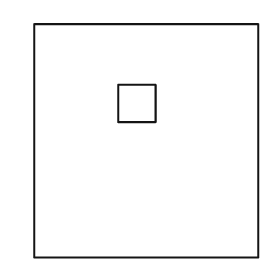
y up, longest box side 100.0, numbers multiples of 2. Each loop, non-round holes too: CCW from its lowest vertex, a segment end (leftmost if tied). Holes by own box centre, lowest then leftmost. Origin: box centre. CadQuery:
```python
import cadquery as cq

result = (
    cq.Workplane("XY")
    .moveTo(-48.0, -50.0)
    .lineTo(48.0, -50.0)
    .lineTo(48.0, 50.0)
    .lineTo(-48.0, 50.0)
    .close()
    .moveTo(-12.0, 8.0)
    .lineTo(4.0, 8.0)
    .lineTo(4.0, 24.0)
    .lineTo(-12.0, 24.0)
    .close()
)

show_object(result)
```